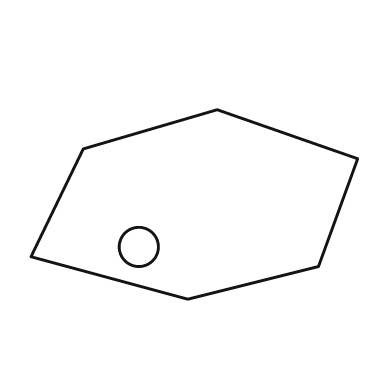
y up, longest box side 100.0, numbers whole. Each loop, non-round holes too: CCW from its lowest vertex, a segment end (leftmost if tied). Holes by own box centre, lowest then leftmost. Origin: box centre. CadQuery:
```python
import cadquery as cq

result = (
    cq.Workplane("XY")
    .moveTo(-2.0, -29.0)
    .lineTo(38.0, -19.0)
    .lineTo(50.0, 14.0)
    .lineTo(7.0, 29.0)
    .lineTo(-34.0, 17.0)
    .lineTo(-50.0, -16.0)
    .close()
    .moveTo(-17.0, -13.0)
    .circle(6.0)
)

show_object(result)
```